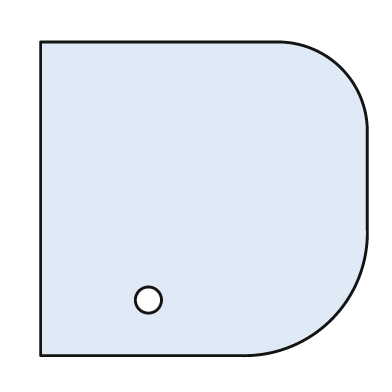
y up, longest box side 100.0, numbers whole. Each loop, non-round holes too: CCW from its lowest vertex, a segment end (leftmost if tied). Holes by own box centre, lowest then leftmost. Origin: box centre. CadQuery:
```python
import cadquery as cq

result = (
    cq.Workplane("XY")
    .moveTo(-50.0, -48.0)
    .lineTo(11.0, -48.0)
    .threePointArc((39.0, -37.0), (50.0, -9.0))
    .lineTo(50.0, 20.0)
    .threePointArc((42.0, 40.0), (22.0, 48.0))
    .lineTo(-50.0, 48.0)
    .close()
    .moveTo(-17.0, -31.0)
    .circle(4.0)
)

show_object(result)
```